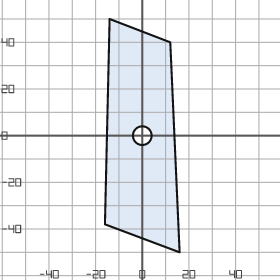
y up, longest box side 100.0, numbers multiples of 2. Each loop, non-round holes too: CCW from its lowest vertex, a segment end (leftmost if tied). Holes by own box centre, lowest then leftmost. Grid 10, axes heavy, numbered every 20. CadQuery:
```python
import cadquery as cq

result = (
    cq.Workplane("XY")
    .moveTo(16.0, -50.0)
    .lineTo(12.0, 40.0)
    .lineTo(-14.0, 50.0)
    .lineTo(-16.0, -38.0)
    .close()
    .moveTo(0.0, 0.0)
    .circle(4.0)
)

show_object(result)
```